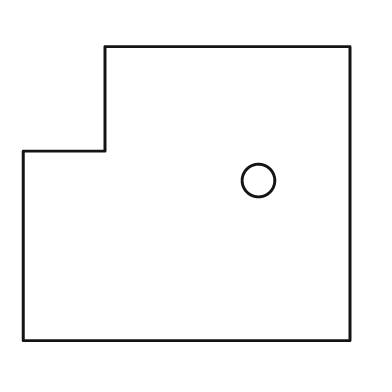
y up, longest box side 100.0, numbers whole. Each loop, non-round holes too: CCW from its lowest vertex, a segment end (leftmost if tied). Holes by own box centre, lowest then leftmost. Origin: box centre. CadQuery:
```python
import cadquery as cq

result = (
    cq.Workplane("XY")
    .moveTo(-50.0, -45.0)
    .lineTo(50.0, -45.0)
    .lineTo(50.0, 45.0)
    .lineTo(-25.0, 45.0)
    .lineTo(-25.0, 13.0)
    .lineTo(-50.0, 13.0)
    .close()
    .moveTo(22.0, 4.0)
    .circle(5.0)
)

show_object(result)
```